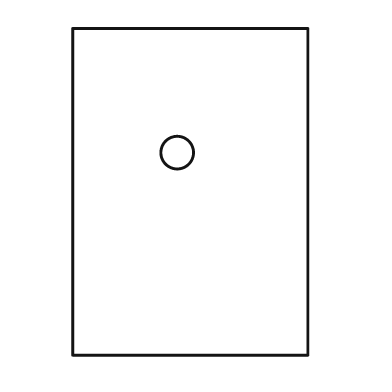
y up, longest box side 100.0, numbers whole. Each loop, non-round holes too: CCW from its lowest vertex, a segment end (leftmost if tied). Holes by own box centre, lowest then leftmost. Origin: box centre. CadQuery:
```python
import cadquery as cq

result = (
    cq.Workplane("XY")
    .moveTo(-36.0, -50.0)
    .lineTo(36.0, -50.0)
    .lineTo(36.0, 50.0)
    .lineTo(-36.0, 50.0)
    .close()
    .moveTo(-4.0, 12.0)
    .circle(5.0)
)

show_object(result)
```